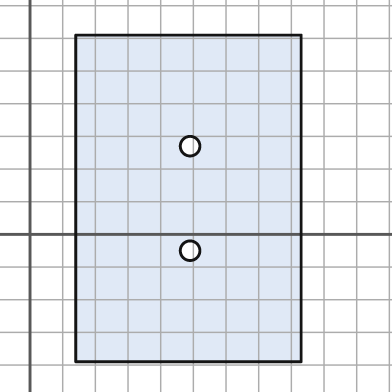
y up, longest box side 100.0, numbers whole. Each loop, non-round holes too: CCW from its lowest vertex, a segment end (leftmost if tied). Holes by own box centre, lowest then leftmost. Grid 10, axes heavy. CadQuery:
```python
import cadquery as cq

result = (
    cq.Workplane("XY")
    .moveTo(14.0, -39.0)
    .lineTo(83.0, -39.0)
    .lineTo(83.0, 61.0)
    .lineTo(14.0, 61.0)
    .close()
    .moveTo(49.0, -5.0)
    .circle(3.0)
    .moveTo(49.0, 27.0)
    .circle(3.0)
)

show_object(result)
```